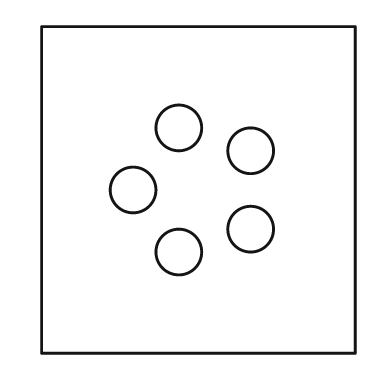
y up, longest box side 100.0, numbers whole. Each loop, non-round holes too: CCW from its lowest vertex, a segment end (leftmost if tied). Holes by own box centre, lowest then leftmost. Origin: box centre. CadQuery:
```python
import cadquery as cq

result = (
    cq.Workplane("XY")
    .moveTo(-48.0, -50.0)
    .lineTo(48.0, -50.0)
    .lineTo(48.0, 50.0)
    .lineTo(-48.0, 50.0)
    .close()
    .moveTo(-6.0, -19.0)
    .circle(7.0)
    .moveTo(16.0, -12.0)
    .circle(7.0)
    .moveTo(-20.0, 0.0)
    .circle(7.0)
    .moveTo(16.0, 12.0)
    .circle(7.0)
    .moveTo(-6.0, 19.0)
    .circle(7.0)
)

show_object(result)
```